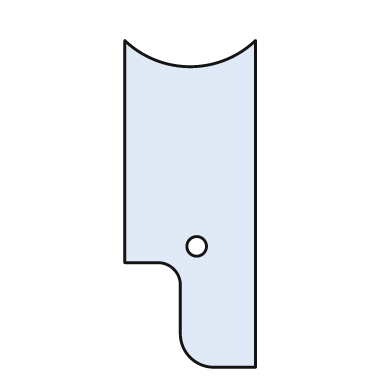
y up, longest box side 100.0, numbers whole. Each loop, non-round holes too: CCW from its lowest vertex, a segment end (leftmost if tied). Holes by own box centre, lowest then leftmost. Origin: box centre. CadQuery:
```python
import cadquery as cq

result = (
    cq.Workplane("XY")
    .moveTo(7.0, -50.0)
    .lineTo(20.0, -50.0)
    .lineTo(20.0, 50.0)
    .threePointArc((0.0, 42.0), (-20.0, 50.0))
    .lineTo(-20.0, -18.0)
    .lineTo(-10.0, -18.0)
    .threePointArc((-5.0, -20.0), (-3.0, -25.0))
    .lineTo(-3.0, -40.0)
    .threePointArc((0.0, -47.0), (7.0, -50.0))
    .close()
    .moveTo(2.0, -13.0)
    .circle(3.0)
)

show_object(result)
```